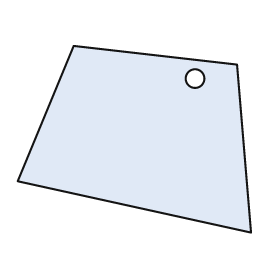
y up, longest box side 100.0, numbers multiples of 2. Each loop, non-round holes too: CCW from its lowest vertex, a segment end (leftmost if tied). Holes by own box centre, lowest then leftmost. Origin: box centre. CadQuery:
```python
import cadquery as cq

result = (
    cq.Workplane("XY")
    .moveTo(50.0, -40.0)
    .lineTo(44.0, 32.0)
    .lineTo(-26.0, 40.0)
    .lineTo(-50.0, -18.0)
    .close()
    .moveTo(26.0, 26.0)
    .circle(4.0)
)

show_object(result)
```